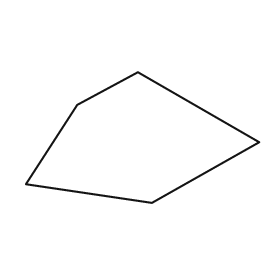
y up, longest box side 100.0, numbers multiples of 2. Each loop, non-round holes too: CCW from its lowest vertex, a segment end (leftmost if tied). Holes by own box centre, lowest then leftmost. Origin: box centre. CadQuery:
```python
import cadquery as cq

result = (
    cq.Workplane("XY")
    .moveTo(4.0, -28.0)
    .lineTo(50.0, -2.0)
    .lineTo(-2.0, 28.0)
    .lineTo(-28.0, 14.0)
    .lineTo(-50.0, -20.0)
    .close()
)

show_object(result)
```